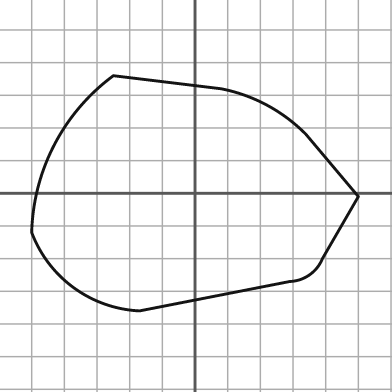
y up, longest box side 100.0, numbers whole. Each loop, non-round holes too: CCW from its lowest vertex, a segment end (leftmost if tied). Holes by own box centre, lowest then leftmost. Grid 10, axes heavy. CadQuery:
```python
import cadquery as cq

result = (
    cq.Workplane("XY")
    .moveTo(-17.0, -36.0)
    .lineTo(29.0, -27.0)
    .threePointArc((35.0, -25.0), (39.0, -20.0))
    .lineTo(50.0, -1.0)
    .lineTo(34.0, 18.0)
    .threePointArc((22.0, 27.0), (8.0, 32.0))
    .lineTo(-25.0, 36.0)
    .threePointArc((-43.0, 15.0), (-50.0, -12.0))
    .threePointArc((-37.0, -29.0), (-17.0, -36.0))
    .close()
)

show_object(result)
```